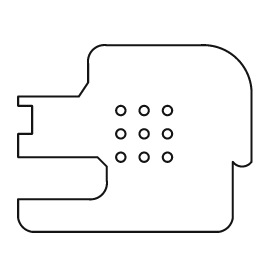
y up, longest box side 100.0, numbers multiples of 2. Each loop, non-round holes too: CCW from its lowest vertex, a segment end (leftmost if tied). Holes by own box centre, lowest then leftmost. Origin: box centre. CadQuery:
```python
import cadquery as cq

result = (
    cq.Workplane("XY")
    .moveTo(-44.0, -40.0)
    .lineTo(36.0, -40.0)
    .threePointArc((40.0, -38.0), (42.0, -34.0))
    .lineTo(42.0, -10.0)
    .threePointArc((46.0, -12.0), (50.0, -10.0))
    .lineTo(50.0, 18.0)
    .threePointArc((44.0, 34.0), (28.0, 40.0))
    .lineTo(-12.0, 40.0)
    .threePointArc((-18.0, 38.0), (-20.0, 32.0))
    .lineTo(-20.0, 24.0)
    .lineTo(-24.0, 18.0)
    .lineTo(-50.0, 18.0)
    .lineTo(-50.0, 14.0)
    .lineTo(-44.0, 14.0)
    .lineTo(-44.0, 2.0)
    .lineTo(-50.0, 2.0)
    .lineTo(-50.0, -8.0)
    .lineTo(-16.0, -8.0)
    .lineTo(-12.0, -12.0)
    .lineTo(-12.0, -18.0)
    .threePointArc((-14.0, -24.0), (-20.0, -26.0))
    .lineTo(-50.0, -26.0)
    .lineTo(-50.0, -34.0)
    .threePointArc((-48.0, -38.0), (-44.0, -40.0))
    .close()
    .moveTo(-6.0, -8.0)
    .circle(2.0)
    .moveTo(4.0, -8.0)
    .circle(2.0)
    .moveTo(14.0, -8.0)
    .circle(2.0)
    .moveTo(-6.0, 2.0)
    .circle(2.0)
    .moveTo(4.0, 2.0)
    .circle(2.0)
    .moveTo(14.0, 2.0)
    .circle(2.0)
    .moveTo(-6.0, 12.0)
    .circle(2.0)
    .moveTo(4.0, 12.0)
    .circle(2.0)
    .moveTo(14.0, 12.0)
    .circle(2.0)
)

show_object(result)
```